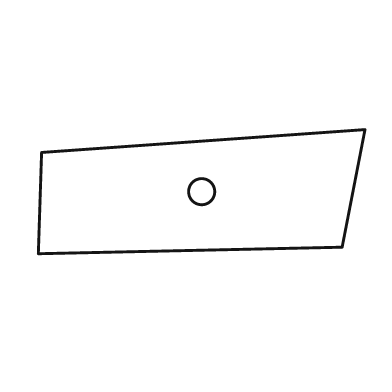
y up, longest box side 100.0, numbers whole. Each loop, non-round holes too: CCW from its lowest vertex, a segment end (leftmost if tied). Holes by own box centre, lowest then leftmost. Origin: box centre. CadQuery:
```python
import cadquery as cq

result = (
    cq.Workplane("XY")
    .moveTo(-50.0, -19.0)
    .lineTo(43.0, -17.0)
    .lineTo(50.0, 19.0)
    .lineTo(-49.0, 12.0)
    .close()
    .moveTo(0.0, 0.0)
    .circle(4.0)
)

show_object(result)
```